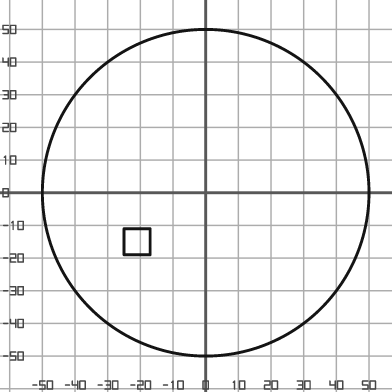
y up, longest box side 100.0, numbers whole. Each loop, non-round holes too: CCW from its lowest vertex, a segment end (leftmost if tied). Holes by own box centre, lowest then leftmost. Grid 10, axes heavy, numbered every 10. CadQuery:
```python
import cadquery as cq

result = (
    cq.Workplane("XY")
    .moveTo(0.0, 0.0)
    .circle(50.0)
    .moveTo(-25.0, -19.0)
    .lineTo(-17.0, -19.0)
    .lineTo(-17.0, -11.0)
    .lineTo(-25.0, -11.0)
    .close()
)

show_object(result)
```